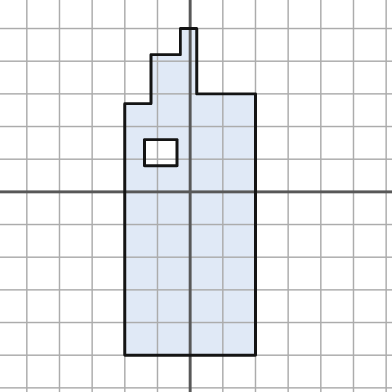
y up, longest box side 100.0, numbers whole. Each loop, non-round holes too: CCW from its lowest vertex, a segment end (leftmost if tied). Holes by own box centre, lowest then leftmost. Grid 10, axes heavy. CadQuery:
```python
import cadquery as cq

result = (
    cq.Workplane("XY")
    .moveTo(-20.0, -50.0)
    .lineTo(20.0, -50.0)
    .lineTo(20.0, 30.0)
    .lineTo(2.0, 30.0)
    .lineTo(2.0, 50.0)
    .lineTo(-3.0, 50.0)
    .lineTo(-3.0, 42.0)
    .lineTo(-12.0, 42.0)
    .lineTo(-12.0, 27.0)
    .lineTo(-20.0, 27.0)
    .close()
    .moveTo(-14.0, 8.0)
    .lineTo(-4.0, 8.0)
    .lineTo(-4.0, 16.0)
    .lineTo(-14.0, 16.0)
    .close()
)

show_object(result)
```